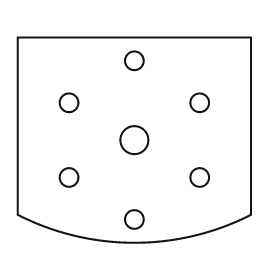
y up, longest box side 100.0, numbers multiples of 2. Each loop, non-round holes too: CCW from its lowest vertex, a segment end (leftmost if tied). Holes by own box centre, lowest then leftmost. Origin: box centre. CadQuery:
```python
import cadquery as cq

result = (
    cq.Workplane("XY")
    .moveTo(-50.0, -32.0)
    .threePointArc((0.0, -44.0), (50.0, -32.0))
    .lineTo(50.0, 44.0)
    .lineTo(-50.0, 44.0)
    .close()
    .moveTo(0.0, -34.0)
    .circle(4.0)
    .moveTo(-28.0, -16.0)
    .circle(4.0)
    .moveTo(28.0, -16.0)
    .circle(4.0)
    .moveTo(0.0, 0.0)
    .circle(6.0)
    .moveTo(-28.0, 16.0)
    .circle(4.0)
    .moveTo(28.0, 16.0)
    .circle(4.0)
    .moveTo(0.0, 34.0)
    .circle(4.0)
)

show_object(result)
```